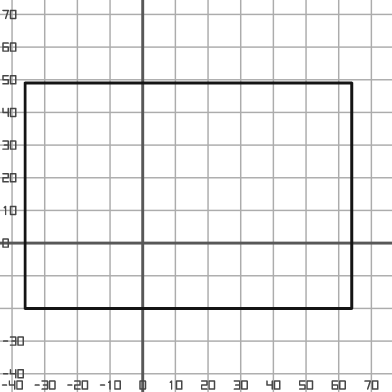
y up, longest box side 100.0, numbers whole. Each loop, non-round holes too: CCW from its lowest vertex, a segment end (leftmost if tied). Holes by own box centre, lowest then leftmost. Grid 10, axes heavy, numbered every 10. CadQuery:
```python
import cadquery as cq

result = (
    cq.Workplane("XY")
    .moveTo(-36.0, -20.0)
    .lineTo(64.0, -20.0)
    .lineTo(64.0, 49.0)
    .lineTo(-36.0, 49.0)
    .close()
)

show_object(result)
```